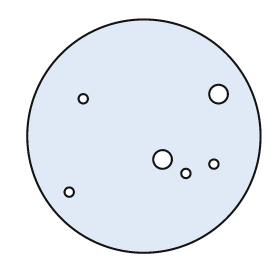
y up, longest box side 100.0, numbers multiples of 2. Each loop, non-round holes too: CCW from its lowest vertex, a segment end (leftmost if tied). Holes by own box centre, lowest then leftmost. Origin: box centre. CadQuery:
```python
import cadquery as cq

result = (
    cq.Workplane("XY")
    .moveTo(0.0, 0.0)
    .circle(50.0)
    .moveTo(-32.0, -24.0)
    .circle(2.0)
    .moveTo(18.0, -16.0)
    .circle(2.0)
    .moveTo(30.0, -12.0)
    .circle(2.0)
    .moveTo(8.0, -10.0)
    .circle(4.0)
    .moveTo(-26.0, 16.0)
    .circle(2.0)
    .moveTo(32.0, 18.0)
    .circle(4.0)
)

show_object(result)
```